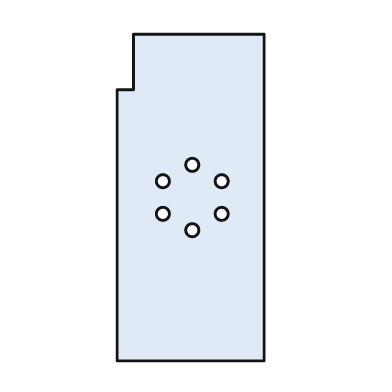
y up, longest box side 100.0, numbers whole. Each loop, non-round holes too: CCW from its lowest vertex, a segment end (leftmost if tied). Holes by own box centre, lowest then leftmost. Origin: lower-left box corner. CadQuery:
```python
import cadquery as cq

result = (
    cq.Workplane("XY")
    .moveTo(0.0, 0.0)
    .lineTo(45.0, 0.0)
    .lineTo(45.0, 100.0)
    .lineTo(5.0, 100.0)
    .lineTo(5.0, 83.0)
    .lineTo(0.0, 83.0)
    .close()
    .moveTo(23.0, 40.0)
    .circle(2.0)
    .moveTo(14.0, 45.0)
    .circle(2.0)
    .moveTo(32.0, 45.0)
    .circle(2.0)
    .moveTo(14.0, 55.0)
    .circle(2.0)
    .moveTo(32.0, 55.0)
    .circle(2.0)
    .moveTo(23.0, 60.0)
    .circle(2.0)
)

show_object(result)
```